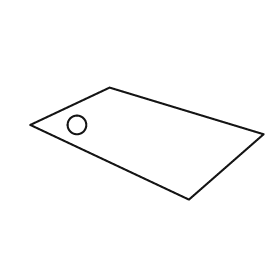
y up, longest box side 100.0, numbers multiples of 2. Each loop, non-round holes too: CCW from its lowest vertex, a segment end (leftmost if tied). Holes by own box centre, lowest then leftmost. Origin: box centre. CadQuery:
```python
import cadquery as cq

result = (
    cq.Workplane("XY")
    .moveTo(18.0, -24.0)
    .lineTo(50.0, 4.0)
    .lineTo(-16.0, 24.0)
    .lineTo(-50.0, 8.0)
    .close()
    .moveTo(-30.0, 8.0)
    .circle(4.0)
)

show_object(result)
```